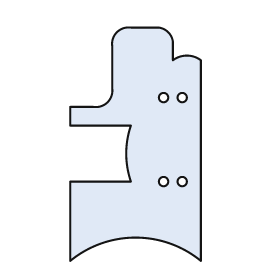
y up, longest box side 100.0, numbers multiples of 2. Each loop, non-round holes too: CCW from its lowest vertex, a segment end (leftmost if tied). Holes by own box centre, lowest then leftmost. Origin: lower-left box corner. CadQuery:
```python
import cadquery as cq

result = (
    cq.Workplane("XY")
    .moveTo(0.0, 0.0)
    .threePointArc((28.0, 10.0), (56.0, 0.0))
    .lineTo(56.0, 86.0)
    .threePointArc((50.0, 88.0), (44.0, 86.0))
    .lineTo(44.0, 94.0)
    .threePointArc((42.0, 98.0), (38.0, 100.0))
    .lineTo(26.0, 100.0)
    .threePointArc((20.0, 98.0), (18.0, 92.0))
    .lineTo(18.0, 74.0)
    .threePointArc((16.0, 68.0), (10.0, 66.0))
    .lineTo(0.0, 66.0)
    .lineTo(0.0, 58.0)
    .lineTo(26.0, 58.0)
    .threePointArc((24.0, 46.0), (26.0, 34.0))
    .lineTo(0.0, 34.0)
    .close()
    .moveTo(40.0, 34.0)
    .circle(2.0)
    .moveTo(48.0, 34.0)
    .circle(2.0)
    .moveTo(40.0, 70.0)
    .circle(2.0)
    .moveTo(48.0, 70.0)
    .circle(2.0)
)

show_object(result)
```